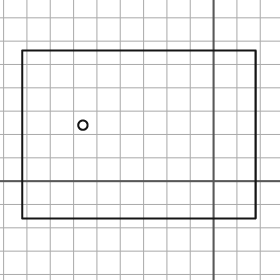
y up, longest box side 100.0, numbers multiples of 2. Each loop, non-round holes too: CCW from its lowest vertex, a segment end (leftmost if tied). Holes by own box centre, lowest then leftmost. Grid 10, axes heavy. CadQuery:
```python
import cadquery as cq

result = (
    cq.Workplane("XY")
    .moveTo(-82.0, -16.0)
    .lineTo(18.0, -16.0)
    .lineTo(18.0, 56.0)
    .lineTo(-82.0, 56.0)
    .close()
    .moveTo(-56.0, 24.0)
    .circle(2.0)
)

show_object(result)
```